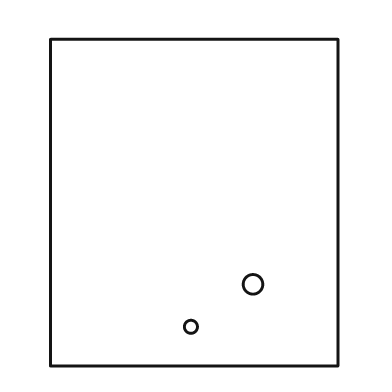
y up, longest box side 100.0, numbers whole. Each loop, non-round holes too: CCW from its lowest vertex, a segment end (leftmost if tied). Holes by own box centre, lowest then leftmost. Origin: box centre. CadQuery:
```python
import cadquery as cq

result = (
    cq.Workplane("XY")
    .moveTo(-44.0, -50.0)
    .lineTo(44.0, -50.0)
    .lineTo(44.0, 50.0)
    .lineTo(-44.0, 50.0)
    .close()
    .moveTo(-1.0, -38.0)
    .circle(2.0)
    .moveTo(18.0, -25.0)
    .circle(3.0)
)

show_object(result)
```